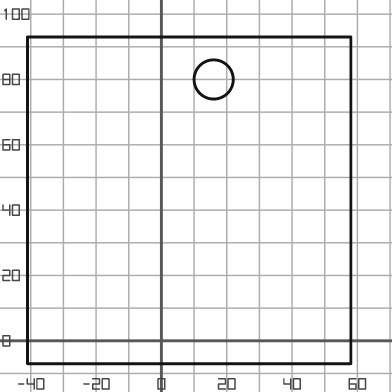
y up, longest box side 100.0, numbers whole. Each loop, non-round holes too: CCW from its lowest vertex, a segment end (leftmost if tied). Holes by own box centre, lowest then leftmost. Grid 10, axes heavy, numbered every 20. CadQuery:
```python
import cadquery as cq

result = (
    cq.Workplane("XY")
    .moveTo(-41.0, -7.0)
    .lineTo(58.0, -7.0)
    .lineTo(58.0, 93.0)
    .lineTo(-41.0, 93.0)
    .close()
    .moveTo(16.0, 80.0)
    .circle(6.0)
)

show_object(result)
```